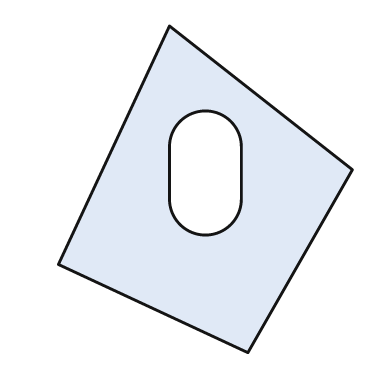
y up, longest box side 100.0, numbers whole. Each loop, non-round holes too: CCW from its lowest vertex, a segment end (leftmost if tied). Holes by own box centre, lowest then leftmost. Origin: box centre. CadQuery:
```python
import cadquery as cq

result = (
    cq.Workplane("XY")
    .moveTo(13.0, -50.0)
    .lineTo(45.0, 6.0)
    .lineTo(-11.0, 50.0)
    .lineTo(-45.0, -23.0)
    .close()
    .moveTo(-11.0, -3.0)
    .threePointArc((0.0, -14.0), (11.0, -3.0))
    .lineTo(11.0, 13.0)
    .threePointArc((0.0, 24.0), (-11.0, 13.0))
    .close()
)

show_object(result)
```